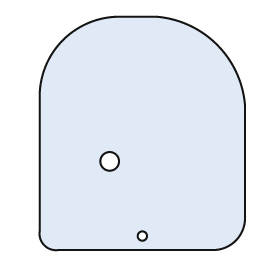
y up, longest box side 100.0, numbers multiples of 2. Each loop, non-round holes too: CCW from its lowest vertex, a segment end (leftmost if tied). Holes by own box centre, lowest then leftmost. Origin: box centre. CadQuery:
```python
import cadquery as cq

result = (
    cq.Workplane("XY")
    .moveTo(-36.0, -50.0)
    .lineTo(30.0, -50.0)
    .threePointArc((40.0, -46.0), (44.0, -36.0))
    .lineTo(44.0, 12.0)
    .threePointArc((32.0, 38.0), (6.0, 50.0))
    .lineTo(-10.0, 50.0)
    .threePointArc((-34.0, 40.0), (-44.0, 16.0))
    .lineTo(-44.0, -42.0)
    .threePointArc((-42.0, -48.0), (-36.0, -50.0))
    .close()
    .moveTo(0.0, -44.0)
    .circle(2.0)
    .moveTo(-14.0, -12.0)
    .circle(4.0)
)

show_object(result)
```